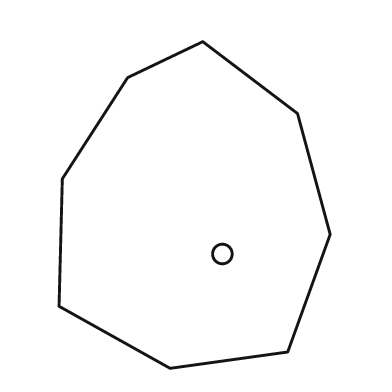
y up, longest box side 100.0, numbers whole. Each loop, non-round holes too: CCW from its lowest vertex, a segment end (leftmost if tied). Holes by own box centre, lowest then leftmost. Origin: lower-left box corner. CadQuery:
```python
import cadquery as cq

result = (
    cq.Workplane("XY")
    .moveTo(34.0, 0.0)
    .lineTo(70.0, 5.0)
    .lineTo(83.0, 41.0)
    .lineTo(73.0, 78.0)
    .lineTo(44.0, 100.0)
    .lineTo(21.0, 89.0)
    .lineTo(1.0, 58.0)
    .lineTo(0.0, 19.0)
    .close()
    .moveTo(50.0, 35.0)
    .circle(3.0)
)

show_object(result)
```